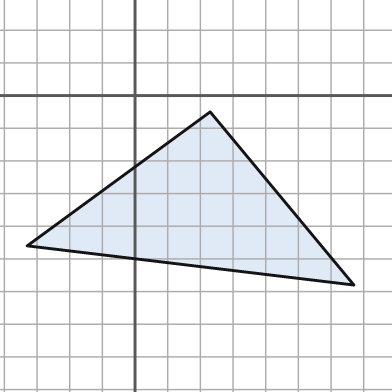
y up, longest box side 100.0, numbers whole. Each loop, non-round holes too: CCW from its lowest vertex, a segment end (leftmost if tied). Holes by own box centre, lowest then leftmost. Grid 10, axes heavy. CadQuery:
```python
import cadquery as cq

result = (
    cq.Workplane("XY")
    .moveTo(67.0, -58.0)
    .lineTo(23.0, -5.0)
    .lineTo(-33.0, -46.0)
    .close()
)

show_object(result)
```